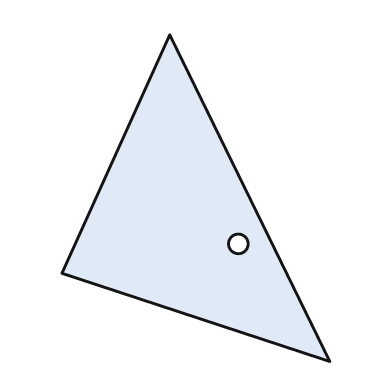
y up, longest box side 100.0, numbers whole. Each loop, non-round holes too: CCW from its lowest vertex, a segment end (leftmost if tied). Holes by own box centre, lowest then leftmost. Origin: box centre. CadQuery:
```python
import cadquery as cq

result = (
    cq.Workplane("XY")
    .moveTo(41.0, -50.0)
    .lineTo(-8.0, 50.0)
    .lineTo(-41.0, -23.0)
    .close()
    .moveTo(13.0, -14.0)
    .circle(3.0)
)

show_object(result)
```